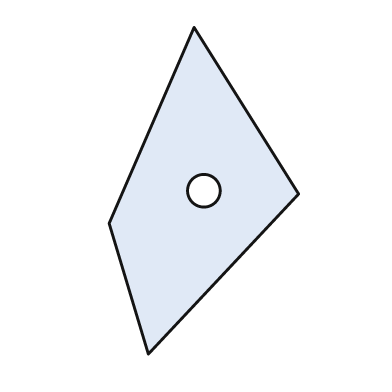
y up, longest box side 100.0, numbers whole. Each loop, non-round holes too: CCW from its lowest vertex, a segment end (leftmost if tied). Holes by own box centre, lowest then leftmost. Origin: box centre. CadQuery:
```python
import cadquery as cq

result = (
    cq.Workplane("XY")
    .moveTo(-17.0, -50.0)
    .lineTo(29.0, -1.0)
    .lineTo(-3.0, 50.0)
    .lineTo(-29.0, -10.0)
    .close()
    .moveTo(0.0, 0.0)
    .circle(5.0)
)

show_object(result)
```